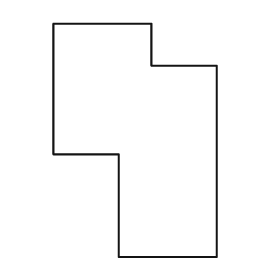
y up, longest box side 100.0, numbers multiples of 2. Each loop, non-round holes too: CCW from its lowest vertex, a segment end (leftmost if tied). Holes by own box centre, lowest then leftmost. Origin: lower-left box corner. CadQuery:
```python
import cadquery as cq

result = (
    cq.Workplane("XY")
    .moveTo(28.0, 0.0)
    .lineTo(70.0, 0.0)
    .lineTo(70.0, 82.0)
    .lineTo(42.0, 82.0)
    .lineTo(42.0, 100.0)
    .lineTo(0.0, 100.0)
    .lineTo(0.0, 44.0)
    .lineTo(28.0, 44.0)
    .close()
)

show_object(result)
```